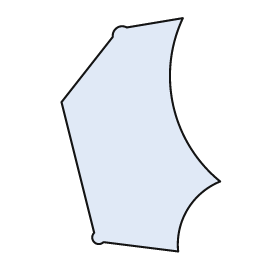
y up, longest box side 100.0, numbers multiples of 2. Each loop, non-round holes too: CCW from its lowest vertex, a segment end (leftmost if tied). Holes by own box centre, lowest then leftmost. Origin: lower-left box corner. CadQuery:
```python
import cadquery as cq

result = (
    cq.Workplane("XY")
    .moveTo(50.0, 0.0)
    .threePointArc((54.0, 18.0), (68.0, 30.0))
    .threePointArc((48.0, 62.0), (52.0, 100.0))
    .lineTo(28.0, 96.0)
    .threePointArc((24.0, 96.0), (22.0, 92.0))
    .lineTo(0.0, 64.0)
    .lineTo(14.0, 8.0)
    .threePointArc((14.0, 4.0), (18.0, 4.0))
    .close()
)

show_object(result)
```